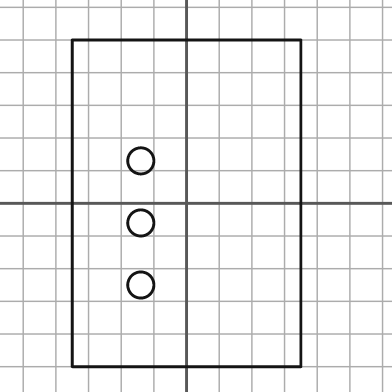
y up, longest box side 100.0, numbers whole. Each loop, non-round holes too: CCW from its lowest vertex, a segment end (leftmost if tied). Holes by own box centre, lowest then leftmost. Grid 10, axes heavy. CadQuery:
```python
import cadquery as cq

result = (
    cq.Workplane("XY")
    .moveTo(-35.0, -50.0)
    .lineTo(35.0, -50.0)
    .lineTo(35.0, 50.0)
    .lineTo(-35.0, 50.0)
    .close()
    .moveTo(-14.0, -25.0)
    .circle(4.0)
    .moveTo(-14.0, -6.0)
    .circle(4.0)
    .moveTo(-14.0, 13.0)
    .circle(4.0)
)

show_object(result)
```